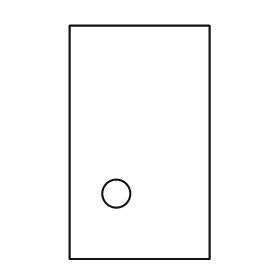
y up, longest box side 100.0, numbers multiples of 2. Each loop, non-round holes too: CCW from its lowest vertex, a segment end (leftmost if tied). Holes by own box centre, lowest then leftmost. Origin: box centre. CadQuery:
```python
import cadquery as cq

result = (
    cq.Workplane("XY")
    .moveTo(-30.0, -50.0)
    .lineTo(30.0, -50.0)
    .lineTo(30.0, 50.0)
    .lineTo(-30.0, 50.0)
    .close()
    .moveTo(-10.0, -22.0)
    .circle(6.0)
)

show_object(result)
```